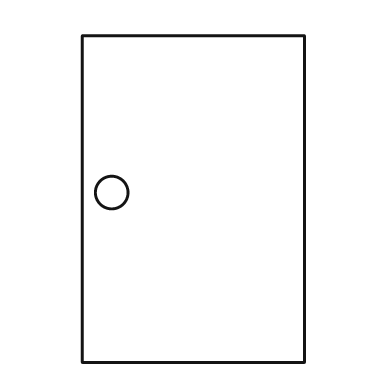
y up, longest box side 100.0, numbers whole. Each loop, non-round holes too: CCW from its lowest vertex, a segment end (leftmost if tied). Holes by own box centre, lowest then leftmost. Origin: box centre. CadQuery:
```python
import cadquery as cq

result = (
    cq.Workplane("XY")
    .moveTo(-34.0, -50.0)
    .lineTo(34.0, -50.0)
    .lineTo(34.0, 50.0)
    .lineTo(-34.0, 50.0)
    .close()
    .moveTo(-25.0, 2.0)
    .circle(5.0)
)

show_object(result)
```